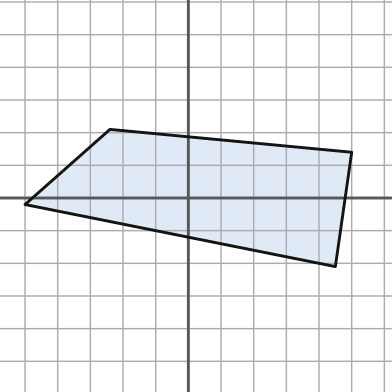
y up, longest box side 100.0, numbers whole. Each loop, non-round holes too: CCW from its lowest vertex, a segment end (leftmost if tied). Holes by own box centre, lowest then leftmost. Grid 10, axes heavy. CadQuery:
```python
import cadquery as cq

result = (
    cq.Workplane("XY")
    .moveTo(45.0, -21.0)
    .lineTo(50.0, 14.0)
    .lineTo(-24.0, 21.0)
    .lineTo(-50.0, -2.0)
    .close()
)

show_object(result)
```